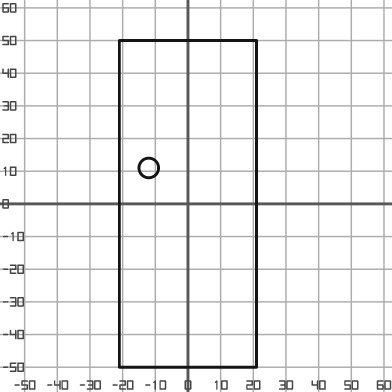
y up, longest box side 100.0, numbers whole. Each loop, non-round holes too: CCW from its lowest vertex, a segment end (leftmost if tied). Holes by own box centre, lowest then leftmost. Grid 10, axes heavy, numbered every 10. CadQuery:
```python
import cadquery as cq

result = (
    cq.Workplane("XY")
    .moveTo(-21.0, -50.0)
    .lineTo(21.0, -50.0)
    .lineTo(21.0, 50.0)
    .lineTo(-21.0, 50.0)
    .close()
    .moveTo(-12.0, 11.0)
    .circle(3.0)
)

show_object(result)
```